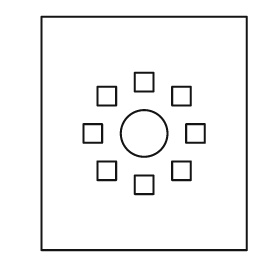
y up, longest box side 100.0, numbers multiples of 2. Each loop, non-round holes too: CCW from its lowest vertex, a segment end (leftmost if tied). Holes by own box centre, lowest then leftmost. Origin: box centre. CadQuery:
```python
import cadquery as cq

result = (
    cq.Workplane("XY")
    .moveTo(-44.0, -50.0)
    .lineTo(44.0, -50.0)
    .lineTo(44.0, 50.0)
    .lineTo(-44.0, 50.0)
    .close()
    .moveTo(-4.0, -26.0)
    .lineTo(4.0, -26.0)
    .lineTo(4.0, -18.0)
    .lineTo(-4.0, -18.0)
    .close()
    .moveTo(-20.0, -20.0)
    .lineTo(-12.0, -20.0)
    .lineTo(-12.0, -12.0)
    .lineTo(-20.0, -12.0)
    .close()
    .moveTo(12.0, -20.0)
    .lineTo(20.0, -20.0)
    .lineTo(20.0, -12.0)
    .lineTo(12.0, -12.0)
    .close()
    .moveTo(-26.0, -4.0)
    .lineTo(-18.0, -4.0)
    .lineTo(-18.0, 4.0)
    .lineTo(-26.0, 4.0)
    .close()
    .moveTo(0.0, 0.0)
    .circle(10.0)
    .moveTo(18.0, -4.0)
    .lineTo(26.0, -4.0)
    .lineTo(26.0, 4.0)
    .lineTo(18.0, 4.0)
    .close()
    .moveTo(-20.0, 12.0)
    .lineTo(-12.0, 12.0)
    .lineTo(-12.0, 20.0)
    .lineTo(-20.0, 20.0)
    .close()
    .moveTo(12.0, 12.0)
    .lineTo(20.0, 12.0)
    .lineTo(20.0, 20.0)
    .lineTo(12.0, 20.0)
    .close()
    .moveTo(-4.0, 18.0)
    .lineTo(4.0, 18.0)
    .lineTo(4.0, 26.0)
    .lineTo(-4.0, 26.0)
    .close()
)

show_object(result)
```